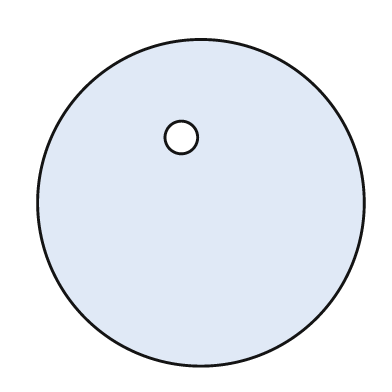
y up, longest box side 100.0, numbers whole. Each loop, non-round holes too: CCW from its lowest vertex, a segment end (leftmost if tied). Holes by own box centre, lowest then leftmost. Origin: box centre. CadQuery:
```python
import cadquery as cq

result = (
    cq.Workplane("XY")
    .moveTo(0.0, 0.0)
    .circle(50.0)
    .moveTo(-6.0, 20.0)
    .circle(5.0)
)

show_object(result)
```